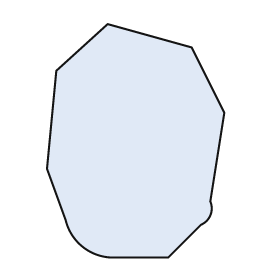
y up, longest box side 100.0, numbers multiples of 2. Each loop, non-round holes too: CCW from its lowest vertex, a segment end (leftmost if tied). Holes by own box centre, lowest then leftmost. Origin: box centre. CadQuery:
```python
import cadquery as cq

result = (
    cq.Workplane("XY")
    .moveTo(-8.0, -50.0)
    .lineTo(14.0, -50.0)
    .lineTo(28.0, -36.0)
    .threePointArc((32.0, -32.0), (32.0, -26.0))
    .lineTo(38.0, 12.0)
    .lineTo(24.0, 40.0)
    .lineTo(-12.0, 50.0)
    .lineTo(-34.0, 30.0)
    .lineTo(-38.0, -12.0)
    .lineTo(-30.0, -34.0)
    .threePointArc((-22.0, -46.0), (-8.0, -50.0))
    .close()
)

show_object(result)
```